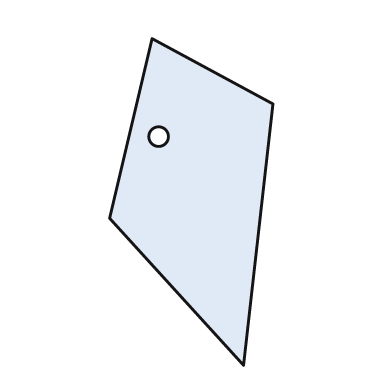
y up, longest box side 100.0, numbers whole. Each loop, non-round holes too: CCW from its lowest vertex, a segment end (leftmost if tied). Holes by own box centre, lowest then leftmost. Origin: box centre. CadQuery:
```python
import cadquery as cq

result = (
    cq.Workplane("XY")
    .moveTo(16.0, -50.0)
    .lineTo(25.0, 30.0)
    .lineTo(-12.0, 50.0)
    .lineTo(-25.0, -5.0)
    .close()
    .moveTo(-10.0, 20.0)
    .circle(3.0)
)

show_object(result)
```